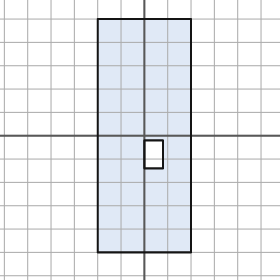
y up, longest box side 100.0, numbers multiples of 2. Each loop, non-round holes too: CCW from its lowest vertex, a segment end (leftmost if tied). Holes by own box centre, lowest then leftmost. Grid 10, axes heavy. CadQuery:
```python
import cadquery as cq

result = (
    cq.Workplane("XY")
    .moveTo(-20.0, -50.0)
    .lineTo(20.0, -50.0)
    .lineTo(20.0, 50.0)
    .lineTo(-20.0, 50.0)
    .close()
    .moveTo(0.0, -14.0)
    .lineTo(8.0, -14.0)
    .lineTo(8.0, -2.0)
    .lineTo(0.0, -2.0)
    .close()
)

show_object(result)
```